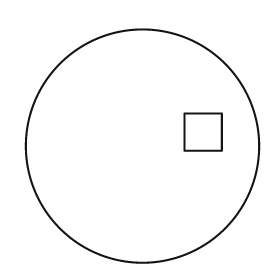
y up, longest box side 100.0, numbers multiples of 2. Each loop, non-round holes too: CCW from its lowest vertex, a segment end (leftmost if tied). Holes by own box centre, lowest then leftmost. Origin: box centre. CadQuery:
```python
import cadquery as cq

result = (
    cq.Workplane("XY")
    .moveTo(0.0, 0.0)
    .circle(50.0)
    .moveTo(18.0, -2.0)
    .lineTo(34.0, -2.0)
    .lineTo(34.0, 14.0)
    .lineTo(18.0, 14.0)
    .close()
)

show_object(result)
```